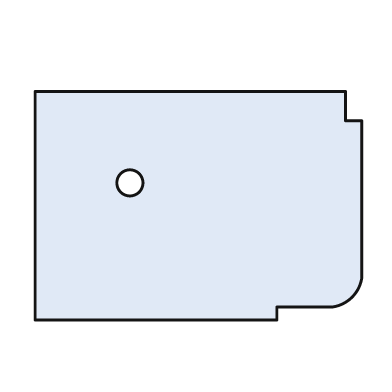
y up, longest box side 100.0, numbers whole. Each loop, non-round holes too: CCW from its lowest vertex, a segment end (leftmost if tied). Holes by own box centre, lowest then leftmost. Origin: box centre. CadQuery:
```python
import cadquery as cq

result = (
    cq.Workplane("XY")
    .moveTo(-50.0, -35.0)
    .lineTo(24.0, -35.0)
    .lineTo(24.0, -31.0)
    .lineTo(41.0, -31.0)
    .threePointArc((47.0, -28.0), (50.0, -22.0))
    .lineTo(50.0, 26.0)
    .lineTo(45.0, 26.0)
    .lineTo(45.0, 35.0)
    .lineTo(-50.0, 35.0)
    .close()
    .moveTo(-21.0, 7.0)
    .circle(4.0)
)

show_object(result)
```